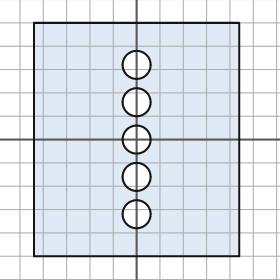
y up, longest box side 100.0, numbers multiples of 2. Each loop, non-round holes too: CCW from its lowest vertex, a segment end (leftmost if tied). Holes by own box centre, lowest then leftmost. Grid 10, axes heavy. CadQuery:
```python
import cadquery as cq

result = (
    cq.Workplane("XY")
    .moveTo(-44.0, -50.0)
    .lineTo(44.0, -50.0)
    .lineTo(44.0, 50.0)
    .lineTo(-44.0, 50.0)
    .close()
    .moveTo(0.0, -32.0)
    .circle(6.0)
    .moveTo(0.0, -16.0)
    .circle(6.0)
    .moveTo(0.0, 0.0)
    .circle(6.0)
    .moveTo(0.0, 16.0)
    .circle(6.0)
    .moveTo(0.0, 32.0)
    .circle(6.0)
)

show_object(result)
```